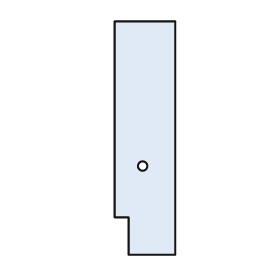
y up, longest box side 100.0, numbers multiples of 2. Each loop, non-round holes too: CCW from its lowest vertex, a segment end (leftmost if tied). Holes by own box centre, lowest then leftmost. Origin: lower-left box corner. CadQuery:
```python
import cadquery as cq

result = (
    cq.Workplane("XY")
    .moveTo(6.0, 0.0)
    .lineTo(26.0, 0.0)
    .lineTo(26.0, 100.0)
    .lineTo(0.0, 100.0)
    .lineTo(0.0, 16.0)
    .lineTo(6.0, 16.0)
    .close()
    .moveTo(12.0, 38.0)
    .circle(2.0)
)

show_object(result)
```